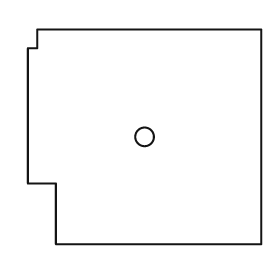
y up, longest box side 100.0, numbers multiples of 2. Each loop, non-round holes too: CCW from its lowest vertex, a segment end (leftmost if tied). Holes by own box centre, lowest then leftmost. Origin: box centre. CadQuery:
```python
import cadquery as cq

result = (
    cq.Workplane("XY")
    .moveTo(-38.0, -46.0)
    .lineTo(50.0, -46.0)
    .lineTo(50.0, 46.0)
    .lineTo(-46.0, 46.0)
    .lineTo(-46.0, 38.0)
    .lineTo(-50.0, 38.0)
    .lineTo(-50.0, -20.0)
    .lineTo(-38.0, -20.0)
    .close()
    .moveTo(0.0, 0.0)
    .circle(4.0)
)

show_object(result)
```